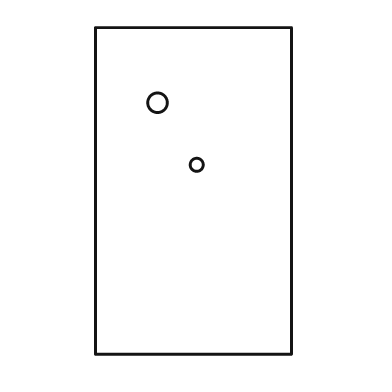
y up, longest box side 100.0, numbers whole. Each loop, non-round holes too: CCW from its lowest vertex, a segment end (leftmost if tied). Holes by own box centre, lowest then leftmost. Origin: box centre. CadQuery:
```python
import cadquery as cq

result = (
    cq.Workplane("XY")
    .moveTo(-30.0, -50.0)
    .lineTo(30.0, -50.0)
    .lineTo(30.0, 50.0)
    .lineTo(-30.0, 50.0)
    .close()
    .moveTo(1.0, 8.0)
    .circle(2.0)
    .moveTo(-11.0, 27.0)
    .circle(3.0)
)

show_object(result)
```